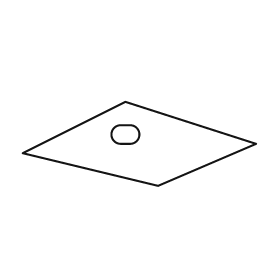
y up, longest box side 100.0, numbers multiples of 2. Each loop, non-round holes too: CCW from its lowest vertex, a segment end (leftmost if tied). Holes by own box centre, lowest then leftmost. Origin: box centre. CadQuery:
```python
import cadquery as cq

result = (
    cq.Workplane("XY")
    .moveTo(8.0, -18.0)
    .lineTo(50.0, 0.0)
    .lineTo(-6.0, 18.0)
    .lineTo(-50.0, -4.0)
    .close()
    .moveTo(-8.0, 0.0)
    .lineTo(-4.0, 0.0)
    .threePointArc((0.0, 4.0), (-4.0, 8.0))
    .lineTo(-8.0, 8.0)
    .threePointArc((-12.0, 4.0), (-8.0, 0.0))
    .close()
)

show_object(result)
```